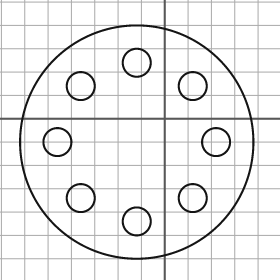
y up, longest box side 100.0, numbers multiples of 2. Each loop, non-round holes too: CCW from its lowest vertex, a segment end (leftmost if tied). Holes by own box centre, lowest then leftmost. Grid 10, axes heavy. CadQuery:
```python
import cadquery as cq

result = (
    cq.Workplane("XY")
    .moveTo(-12.0, -10.0)
    .circle(50.0)
    .moveTo(-12.0, -44.0)
    .circle(6.0)
    .moveTo(-36.0, -34.0)
    .circle(6.0)
    .moveTo(12.0, -34.0)
    .circle(6.0)
    .moveTo(-46.0, -10.0)
    .circle(6.0)
    .moveTo(22.0, -10.0)
    .circle(6.0)
    .moveTo(-36.0, 14.0)
    .circle(6.0)
    .moveTo(12.0, 14.0)
    .circle(6.0)
    .moveTo(-12.0, 24.0)
    .circle(6.0)
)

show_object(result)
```